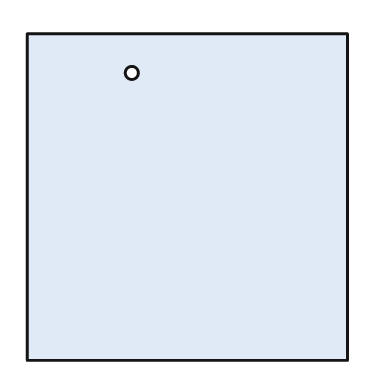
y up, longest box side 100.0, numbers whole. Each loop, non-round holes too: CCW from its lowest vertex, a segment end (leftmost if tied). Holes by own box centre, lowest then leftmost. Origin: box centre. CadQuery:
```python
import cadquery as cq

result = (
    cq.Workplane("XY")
    .moveTo(-49.0, -50.0)
    .lineTo(49.0, -50.0)
    .lineTo(49.0, 50.0)
    .lineTo(-49.0, 50.0)
    .close()
    .moveTo(-17.0, 38.0)
    .circle(2.0)
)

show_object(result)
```